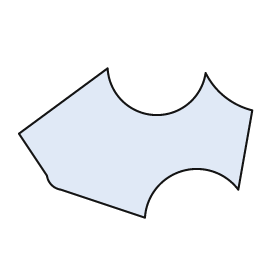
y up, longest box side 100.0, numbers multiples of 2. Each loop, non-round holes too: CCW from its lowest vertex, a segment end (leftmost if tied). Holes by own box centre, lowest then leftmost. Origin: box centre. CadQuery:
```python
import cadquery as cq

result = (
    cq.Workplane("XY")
    .moveTo(4.0, -32.0)
    .threePointArc((20.0, -12.0), (44.0, -20.0))
    .lineTo(50.0, 14.0)
    .threePointArc((38.0, 20.0), (30.0, 30.0))
    .threePointArc((8.0, 12.0), (-12.0, 32.0))
    .lineTo(-50.0, 4.0)
    .lineTo(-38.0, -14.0)
    .threePointArc((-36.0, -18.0), (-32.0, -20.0))
    .close()
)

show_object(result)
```